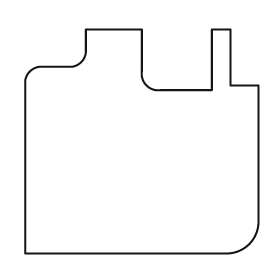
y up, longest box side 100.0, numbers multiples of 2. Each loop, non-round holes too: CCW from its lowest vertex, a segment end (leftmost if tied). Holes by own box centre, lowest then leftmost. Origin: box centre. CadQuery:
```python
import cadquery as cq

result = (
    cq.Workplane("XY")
    .moveTo(-50.0, -48.0)
    .lineTo(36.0, -48.0)
    .threePointArc((46.0, -44.0), (50.0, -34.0))
    .lineTo(50.0, 24.0)
    .lineTo(38.0, 24.0)
    .lineTo(38.0, 48.0)
    .lineTo(30.0, 48.0)
    .lineTo(30.0, 22.0)
    .lineTo(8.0, 22.0)
    .threePointArc((2.0, 24.0), (0.0, 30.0))
    .lineTo(0.0, 48.0)
    .lineTo(-24.0, 48.0)
    .lineTo(-24.0, 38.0)
    .threePointArc((-26.0, 34.0), (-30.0, 32.0))
    .lineTo(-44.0, 32.0)
    .threePointArc((-48.0, 30.0), (-50.0, 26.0))
    .close()
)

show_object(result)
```